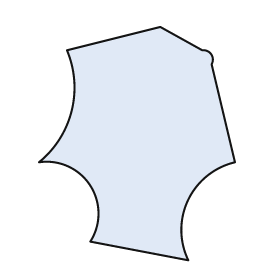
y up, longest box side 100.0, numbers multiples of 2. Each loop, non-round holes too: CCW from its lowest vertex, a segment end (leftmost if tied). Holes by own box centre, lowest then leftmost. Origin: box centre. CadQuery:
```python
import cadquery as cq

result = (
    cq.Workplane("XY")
    .moveTo(22.0, -50.0)
    .threePointArc((22.0, -24.0), (42.0, -8.0))
    .lineTo(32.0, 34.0)
    .threePointArc((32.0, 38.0), (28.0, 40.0))
    .lineTo(10.0, 50.0)
    .lineTo(-30.0, 40.0)
    .threePointArc((-28.0, 14.0), (-42.0, -8.0))
    .threePointArc((-20.0, -18.0), (-20.0, -42.0))
    .close()
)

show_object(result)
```